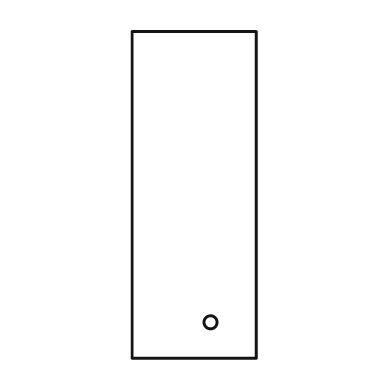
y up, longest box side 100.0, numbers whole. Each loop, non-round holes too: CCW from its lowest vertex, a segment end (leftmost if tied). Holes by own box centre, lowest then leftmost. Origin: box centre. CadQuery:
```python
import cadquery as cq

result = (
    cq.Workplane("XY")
    .moveTo(-19.0, -50.0)
    .lineTo(19.0, -50.0)
    .lineTo(19.0, 50.0)
    .lineTo(-19.0, 50.0)
    .close()
    .moveTo(5.0, -39.0)
    .circle(2.0)
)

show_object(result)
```